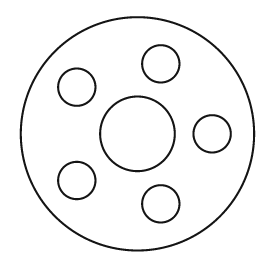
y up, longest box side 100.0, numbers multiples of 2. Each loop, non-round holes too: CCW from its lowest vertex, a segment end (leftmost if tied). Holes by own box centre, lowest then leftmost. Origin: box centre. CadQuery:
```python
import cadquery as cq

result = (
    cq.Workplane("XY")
    .moveTo(0.0, 0.0)
    .circle(50.0)
    .moveTo(10.0, -30.0)
    .circle(8.0)
    .moveTo(-26.0, -20.0)
    .circle(8.0)
    .moveTo(0.0, 0.0)
    .circle(16.0)
    .moveTo(32.0, 0.0)
    .circle(8.0)
    .moveTo(-26.0, 20.0)
    .circle(8.0)
    .moveTo(10.0, 30.0)
    .circle(8.0)
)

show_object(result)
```